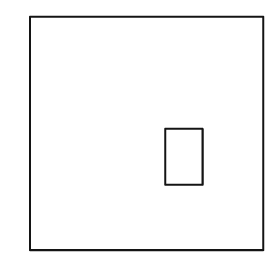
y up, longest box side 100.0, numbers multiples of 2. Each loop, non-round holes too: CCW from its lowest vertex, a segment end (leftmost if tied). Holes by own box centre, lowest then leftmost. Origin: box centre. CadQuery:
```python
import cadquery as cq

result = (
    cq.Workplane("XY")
    .moveTo(-50.0, -50.0)
    .lineTo(50.0, -50.0)
    .lineTo(50.0, 50.0)
    .lineTo(-50.0, 50.0)
    .close()
    .moveTo(8.0, -22.0)
    .lineTo(24.0, -22.0)
    .lineTo(24.0, 2.0)
    .lineTo(8.0, 2.0)
    .close()
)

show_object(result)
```